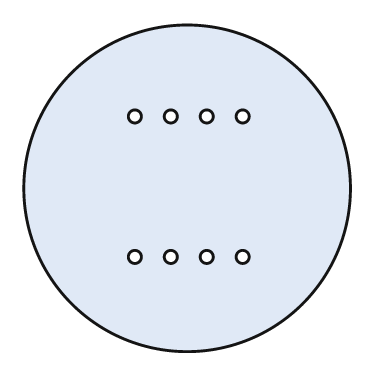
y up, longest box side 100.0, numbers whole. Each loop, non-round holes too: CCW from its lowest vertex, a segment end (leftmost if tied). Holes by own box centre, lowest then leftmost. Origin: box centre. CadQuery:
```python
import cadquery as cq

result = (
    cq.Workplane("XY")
    .moveTo(0.0, 0.0)
    .circle(50.0)
    .moveTo(-16.0, -21.0)
    .circle(2.0)
    .moveTo(-5.0, -21.0)
    .circle(2.0)
    .moveTo(6.0, -21.0)
    .circle(2.0)
    .moveTo(17.0, -21.0)
    .circle(2.0)
    .moveTo(-16.0, 22.0)
    .circle(2.0)
    .moveTo(-5.0, 22.0)
    .circle(2.0)
    .moveTo(6.0, 22.0)
    .circle(2.0)
    .moveTo(17.0, 22.0)
    .circle(2.0)
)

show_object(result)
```